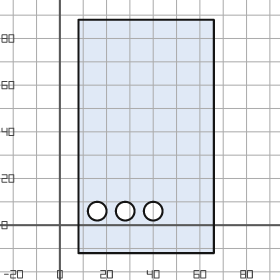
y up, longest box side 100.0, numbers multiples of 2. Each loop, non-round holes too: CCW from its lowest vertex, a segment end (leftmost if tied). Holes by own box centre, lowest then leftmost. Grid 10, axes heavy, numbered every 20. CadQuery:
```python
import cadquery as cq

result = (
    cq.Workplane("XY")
    .moveTo(8.0, -12.0)
    .lineTo(66.0, -12.0)
    .lineTo(66.0, 88.0)
    .lineTo(8.0, 88.0)
    .close()
    .moveTo(16.0, 6.0)
    .circle(4.0)
    .moveTo(28.0, 6.0)
    .circle(4.0)
    .moveTo(40.0, 6.0)
    .circle(4.0)
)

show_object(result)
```